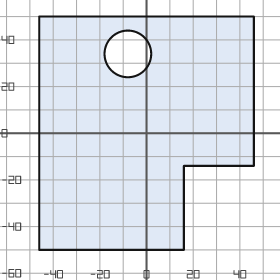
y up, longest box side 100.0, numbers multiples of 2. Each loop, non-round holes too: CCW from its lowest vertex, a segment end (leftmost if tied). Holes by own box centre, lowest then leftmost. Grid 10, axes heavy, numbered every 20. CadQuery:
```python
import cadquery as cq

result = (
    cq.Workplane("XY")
    .moveTo(-46.0, -50.0)
    .lineTo(16.0, -50.0)
    .lineTo(16.0, -14.0)
    .lineTo(46.0, -14.0)
    .lineTo(46.0, 50.0)
    .lineTo(-46.0, 50.0)
    .close()
    .moveTo(-8.0, 34.0)
    .circle(10.0)
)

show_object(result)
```